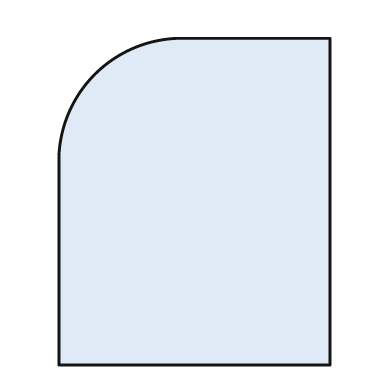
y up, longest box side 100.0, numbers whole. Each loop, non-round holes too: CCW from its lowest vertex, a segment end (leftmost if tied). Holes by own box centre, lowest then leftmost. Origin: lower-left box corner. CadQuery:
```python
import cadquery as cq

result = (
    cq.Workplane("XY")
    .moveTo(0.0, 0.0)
    .lineTo(83.0, 0.0)
    .lineTo(83.0, 100.0)
    .lineTo(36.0, 100.0)
    .threePointArc((11.0, 89.0), (0.0, 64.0))
    .close()
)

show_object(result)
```